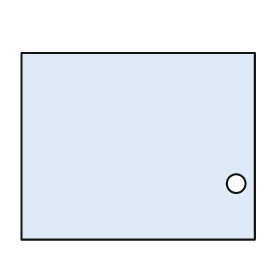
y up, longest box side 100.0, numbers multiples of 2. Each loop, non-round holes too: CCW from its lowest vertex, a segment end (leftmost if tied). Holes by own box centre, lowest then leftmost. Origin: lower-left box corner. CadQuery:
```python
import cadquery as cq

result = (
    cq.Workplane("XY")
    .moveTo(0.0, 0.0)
    .lineTo(100.0, 0.0)
    .lineTo(100.0, 80.0)
    .lineTo(0.0, 80.0)
    .close()
    .moveTo(92.0, 24.0)
    .circle(4.0)
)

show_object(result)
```